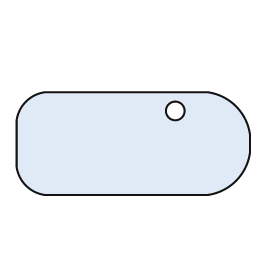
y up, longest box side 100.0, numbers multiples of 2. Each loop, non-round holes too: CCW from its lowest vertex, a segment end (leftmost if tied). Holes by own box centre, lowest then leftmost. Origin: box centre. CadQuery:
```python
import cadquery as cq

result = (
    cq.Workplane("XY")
    .moveTo(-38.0, -22.0)
    .lineTo(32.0, -22.0)
    .threePointArc((44.0, -16.0), (50.0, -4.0))
    .lineTo(50.0, 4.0)
    .threePointArc((44.0, 16.0), (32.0, 22.0))
    .lineTo(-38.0, 22.0)
    .threePointArc((-46.0, 18.0), (-50.0, 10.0))
    .lineTo(-50.0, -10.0)
    .threePointArc((-46.0, -18.0), (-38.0, -22.0))
    .close()
    .moveTo(18.0, 14.0)
    .circle(4.0)
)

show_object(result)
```